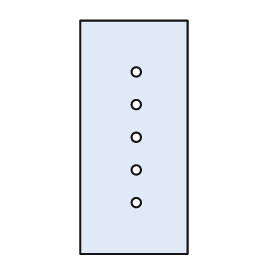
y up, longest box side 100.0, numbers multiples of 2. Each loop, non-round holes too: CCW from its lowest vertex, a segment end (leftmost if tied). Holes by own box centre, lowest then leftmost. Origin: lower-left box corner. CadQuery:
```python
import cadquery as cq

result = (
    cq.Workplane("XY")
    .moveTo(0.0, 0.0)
    .lineTo(46.0, 0.0)
    .lineTo(46.0, 100.0)
    .lineTo(0.0, 100.0)
    .close()
    .moveTo(24.0, 22.0)
    .circle(2.0)
    .moveTo(24.0, 36.0)
    .circle(2.0)
    .moveTo(24.0, 50.0)
    .circle(2.0)
    .moveTo(24.0, 64.0)
    .circle(2.0)
    .moveTo(24.0, 78.0)
    .circle(2.0)
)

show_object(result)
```